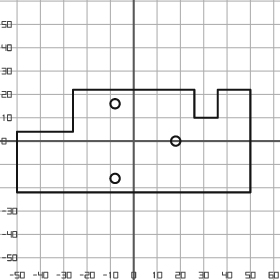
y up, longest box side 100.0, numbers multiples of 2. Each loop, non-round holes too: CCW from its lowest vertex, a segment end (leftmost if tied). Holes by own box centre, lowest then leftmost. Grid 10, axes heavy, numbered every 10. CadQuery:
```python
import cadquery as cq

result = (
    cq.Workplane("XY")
    .moveTo(-50.0, -22.0)
    .lineTo(50.0, -22.0)
    .lineTo(50.0, 22.0)
    .lineTo(36.0, 22.0)
    .lineTo(36.0, 10.0)
    .lineTo(26.0, 10.0)
    .lineTo(26.0, 22.0)
    .lineTo(-26.0, 22.0)
    .lineTo(-26.0, 4.0)
    .lineTo(-50.0, 4.0)
    .close()
    .moveTo(-8.0, -16.0)
    .circle(2.0)
    .moveTo(18.0, 0.0)
    .circle(2.0)
    .moveTo(-8.0, 16.0)
    .circle(2.0)
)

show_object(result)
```